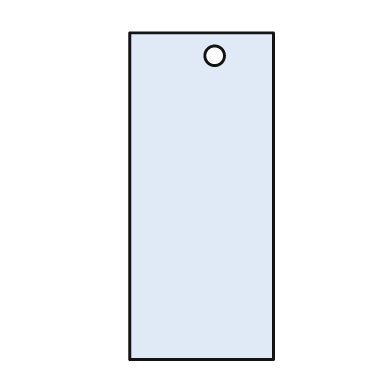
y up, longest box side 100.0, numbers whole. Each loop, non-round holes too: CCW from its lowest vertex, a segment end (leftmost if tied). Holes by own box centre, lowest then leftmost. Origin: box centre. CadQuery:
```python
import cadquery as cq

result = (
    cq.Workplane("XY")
    .moveTo(-22.0, -50.0)
    .lineTo(22.0, -50.0)
    .lineTo(22.0, 50.0)
    .lineTo(-22.0, 50.0)
    .close()
    .moveTo(4.0, 43.0)
    .circle(3.0)
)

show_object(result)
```